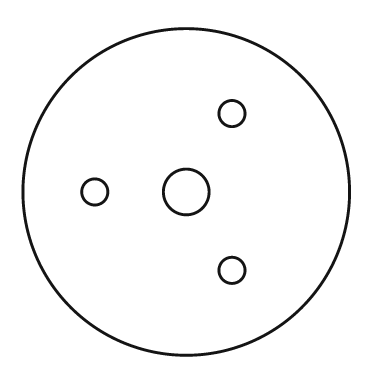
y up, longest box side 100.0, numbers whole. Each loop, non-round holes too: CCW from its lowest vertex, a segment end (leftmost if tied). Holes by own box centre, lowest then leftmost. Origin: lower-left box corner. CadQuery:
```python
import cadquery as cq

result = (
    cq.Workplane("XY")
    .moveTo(50.0, 50.0)
    .circle(50.0)
    .moveTo(64.0, 26.0)
    .circle(4.0)
    .moveTo(22.0, 50.0)
    .circle(4.0)
    .moveTo(50.0, 50.0)
    .circle(7.0)
    .moveTo(64.0, 74.0)
    .circle(4.0)
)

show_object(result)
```